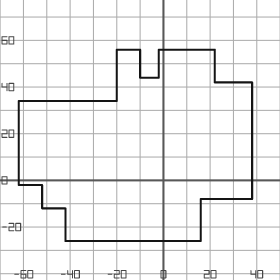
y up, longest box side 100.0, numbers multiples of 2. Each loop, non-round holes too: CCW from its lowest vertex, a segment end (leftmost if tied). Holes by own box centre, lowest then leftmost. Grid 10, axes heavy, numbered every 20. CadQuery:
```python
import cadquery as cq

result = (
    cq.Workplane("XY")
    .moveTo(-42.0, -26.0)
    .lineTo(16.0, -26.0)
    .lineTo(16.0, -8.0)
    .lineTo(38.0, -8.0)
    .lineTo(38.0, 42.0)
    .lineTo(22.0, 42.0)
    .lineTo(22.0, 56.0)
    .lineTo(-2.0, 56.0)
    .lineTo(-2.0, 44.0)
    .lineTo(-10.0, 44.0)
    .lineTo(-10.0, 56.0)
    .lineTo(-20.0, 56.0)
    .lineTo(-20.0, 34.0)
    .lineTo(-62.0, 34.0)
    .lineTo(-62.0, -2.0)
    .lineTo(-52.0, -2.0)
    .lineTo(-52.0, -12.0)
    .lineTo(-42.0, -12.0)
    .close()
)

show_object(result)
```